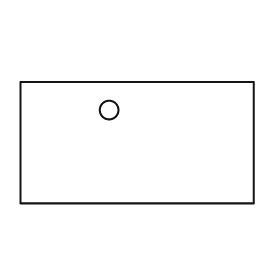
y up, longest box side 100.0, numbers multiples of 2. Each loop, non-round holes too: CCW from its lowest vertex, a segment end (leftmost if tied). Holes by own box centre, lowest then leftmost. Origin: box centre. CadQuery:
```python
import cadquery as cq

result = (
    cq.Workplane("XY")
    .moveTo(-50.0, -26.0)
    .lineTo(50.0, -26.0)
    .lineTo(50.0, 26.0)
    .lineTo(-50.0, 26.0)
    .close()
    .moveTo(-12.0, 14.0)
    .circle(4.0)
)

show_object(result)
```